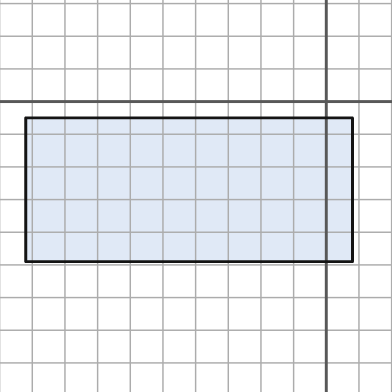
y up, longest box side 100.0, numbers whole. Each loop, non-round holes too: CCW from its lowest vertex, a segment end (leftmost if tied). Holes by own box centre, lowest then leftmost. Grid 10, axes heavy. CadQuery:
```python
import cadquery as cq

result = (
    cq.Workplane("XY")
    .moveTo(-92.0, -49.0)
    .lineTo(8.0, -49.0)
    .lineTo(8.0, -5.0)
    .lineTo(-92.0, -5.0)
    .close()
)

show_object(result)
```